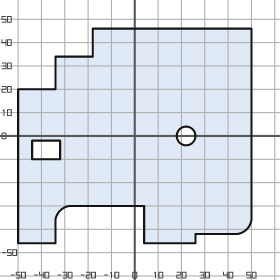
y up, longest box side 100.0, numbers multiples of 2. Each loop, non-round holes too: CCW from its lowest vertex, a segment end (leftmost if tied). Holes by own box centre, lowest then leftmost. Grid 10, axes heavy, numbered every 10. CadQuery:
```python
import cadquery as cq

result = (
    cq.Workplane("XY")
    .moveTo(-50.0, -46.0)
    .lineTo(-34.0, -46.0)
    .lineTo(-34.0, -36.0)
    .threePointArc((-32.0, -32.0), (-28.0, -30.0))
    .lineTo(4.0, -30.0)
    .lineTo(4.0, -46.0)
    .lineTo(26.0, -46.0)
    .lineTo(26.0, -42.0)
    .lineTo(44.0, -42.0)
    .threePointArc((48.0, -40.0), (50.0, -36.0))
    .lineTo(50.0, 46.0)
    .lineTo(-18.0, 46.0)
    .lineTo(-18.0, 34.0)
    .lineTo(-34.0, 34.0)
    .lineTo(-34.0, 20.0)
    .lineTo(-50.0, 20.0)
    .close()
    .moveTo(-44.0, -10.0)
    .lineTo(-32.0, -10.0)
    .lineTo(-32.0, -2.0)
    .lineTo(-44.0, -2.0)
    .close()
    .moveTo(22.0, 0.0)
    .circle(4.0)
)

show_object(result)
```